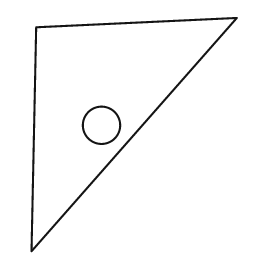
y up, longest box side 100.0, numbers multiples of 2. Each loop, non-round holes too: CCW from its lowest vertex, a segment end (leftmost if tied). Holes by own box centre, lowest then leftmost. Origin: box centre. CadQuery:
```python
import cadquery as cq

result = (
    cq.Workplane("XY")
    .moveTo(-44.0, -50.0)
    .lineTo(44.0, 50.0)
    .lineTo(-42.0, 46.0)
    .close()
    .moveTo(-14.0, 4.0)
    .circle(8.0)
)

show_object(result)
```